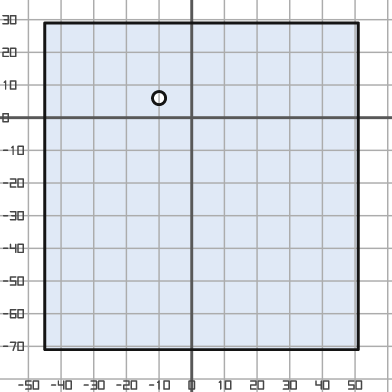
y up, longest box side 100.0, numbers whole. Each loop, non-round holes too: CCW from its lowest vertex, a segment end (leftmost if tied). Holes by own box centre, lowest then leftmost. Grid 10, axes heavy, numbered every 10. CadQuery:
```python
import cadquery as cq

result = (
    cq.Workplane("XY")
    .moveTo(-45.0, -71.0)
    .lineTo(51.0, -71.0)
    .lineTo(51.0, 29.0)
    .lineTo(-45.0, 29.0)
    .close()
    .moveTo(-10.0, 6.0)
    .circle(2.0)
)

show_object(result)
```